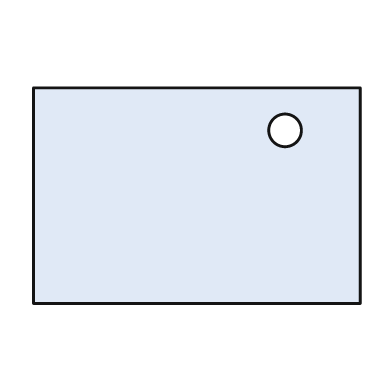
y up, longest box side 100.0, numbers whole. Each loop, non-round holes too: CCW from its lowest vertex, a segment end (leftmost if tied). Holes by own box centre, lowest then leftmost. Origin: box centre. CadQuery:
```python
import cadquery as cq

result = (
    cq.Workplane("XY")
    .moveTo(-50.0, -33.0)
    .lineTo(50.0, -33.0)
    .lineTo(50.0, 33.0)
    .lineTo(-50.0, 33.0)
    .close()
    .moveTo(27.0, 20.0)
    .circle(5.0)
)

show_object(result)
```